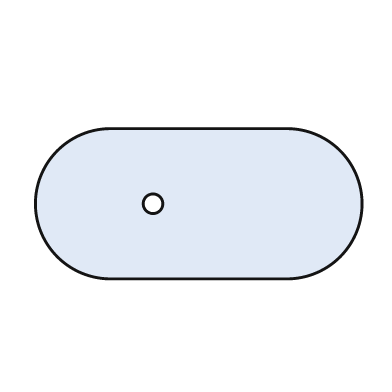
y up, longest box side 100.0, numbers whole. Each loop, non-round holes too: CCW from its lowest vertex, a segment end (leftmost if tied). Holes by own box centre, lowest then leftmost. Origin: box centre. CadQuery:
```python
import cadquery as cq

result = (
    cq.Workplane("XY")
    .moveTo(-27.0, -23.0)
    .lineTo(27.0, -23.0)
    .threePointArc((50.0, 0.0), (27.0, 23.0))
    .lineTo(-27.0, 23.0)
    .threePointArc((-50.0, 0.0), (-27.0, -23.0))
    .close()
    .moveTo(-14.0, 0.0)
    .circle(3.0)
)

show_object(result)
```